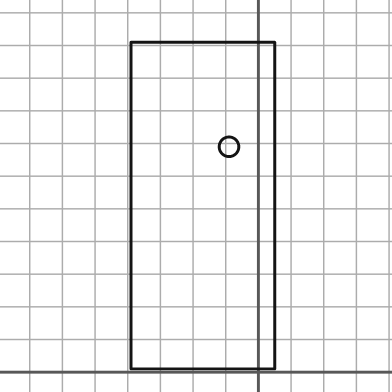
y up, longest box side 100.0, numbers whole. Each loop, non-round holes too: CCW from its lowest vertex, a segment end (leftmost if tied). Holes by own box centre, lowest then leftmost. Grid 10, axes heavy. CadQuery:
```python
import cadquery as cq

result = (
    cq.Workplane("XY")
    .moveTo(-39.0, 1.0)
    .lineTo(5.0, 1.0)
    .lineTo(5.0, 101.0)
    .lineTo(-39.0, 101.0)
    .close()
    .moveTo(-9.0, 69.0)
    .circle(3.0)
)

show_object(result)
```